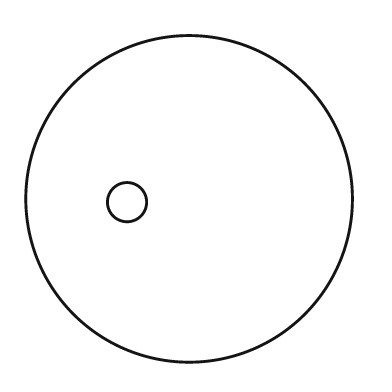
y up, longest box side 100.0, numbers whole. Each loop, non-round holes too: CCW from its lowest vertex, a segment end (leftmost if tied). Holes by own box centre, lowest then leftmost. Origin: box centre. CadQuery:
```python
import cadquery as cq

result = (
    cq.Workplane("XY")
    .moveTo(0.0, 0.0)
    .circle(50.0)
    .moveTo(-19.0, -1.0)
    .circle(6.0)
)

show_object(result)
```